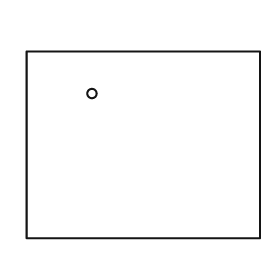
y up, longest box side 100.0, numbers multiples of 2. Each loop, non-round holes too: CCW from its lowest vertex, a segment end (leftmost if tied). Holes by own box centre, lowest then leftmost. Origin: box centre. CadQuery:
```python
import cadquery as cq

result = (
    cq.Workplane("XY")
    .moveTo(-50.0, -40.0)
    .lineTo(50.0, -40.0)
    .lineTo(50.0, 40.0)
    .lineTo(-50.0, 40.0)
    .close()
    .moveTo(-22.0, 22.0)
    .circle(2.0)
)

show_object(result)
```